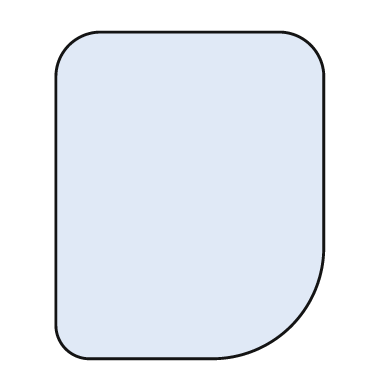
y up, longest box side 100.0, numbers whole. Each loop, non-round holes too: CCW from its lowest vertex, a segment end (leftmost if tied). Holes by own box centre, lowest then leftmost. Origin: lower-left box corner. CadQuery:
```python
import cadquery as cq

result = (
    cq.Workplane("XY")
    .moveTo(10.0, 0.0)
    .lineTo(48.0, 0.0)
    .threePointArc((72.0, 10.0), (82.0, 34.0))
    .lineTo(82.0, 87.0)
    .threePointArc((78.0, 96.0), (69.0, 100.0))
    .lineTo(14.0, 100.0)
    .threePointArc((4.0, 96.0), (0.0, 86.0))
    .lineTo(0.0, 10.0)
    .threePointArc((3.0, 3.0), (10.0, 0.0))
    .close()
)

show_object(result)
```